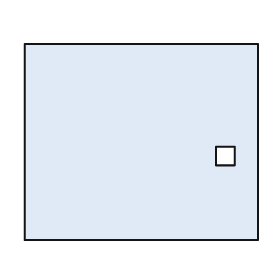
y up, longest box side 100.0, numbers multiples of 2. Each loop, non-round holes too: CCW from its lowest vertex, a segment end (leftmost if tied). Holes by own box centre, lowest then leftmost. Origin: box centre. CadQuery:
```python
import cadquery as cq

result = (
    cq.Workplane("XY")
    .moveTo(-50.0, -42.0)
    .lineTo(50.0, -42.0)
    .lineTo(50.0, 42.0)
    .lineTo(-50.0, 42.0)
    .close()
    .moveTo(32.0, -10.0)
    .lineTo(40.0, -10.0)
    .lineTo(40.0, -2.0)
    .lineTo(32.0, -2.0)
    .close()
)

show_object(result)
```